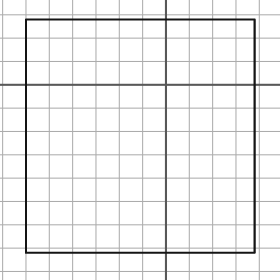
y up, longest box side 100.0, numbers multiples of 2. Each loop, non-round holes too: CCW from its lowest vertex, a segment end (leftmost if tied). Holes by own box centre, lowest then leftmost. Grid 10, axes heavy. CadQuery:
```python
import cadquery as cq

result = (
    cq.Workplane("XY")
    .moveTo(-60.0, -72.0)
    .lineTo(38.0, -72.0)
    .lineTo(38.0, 28.0)
    .lineTo(-60.0, 28.0)
    .close()
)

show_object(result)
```